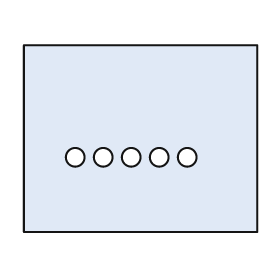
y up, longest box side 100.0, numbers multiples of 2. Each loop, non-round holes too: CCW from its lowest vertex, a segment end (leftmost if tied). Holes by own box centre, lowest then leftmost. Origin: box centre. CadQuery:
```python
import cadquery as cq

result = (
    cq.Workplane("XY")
    .moveTo(-50.0, -40.0)
    .lineTo(50.0, -40.0)
    .lineTo(50.0, 40.0)
    .lineTo(-50.0, 40.0)
    .close()
    .moveTo(-28.0, -8.0)
    .circle(4.0)
    .moveTo(-16.0, -8.0)
    .circle(4.0)
    .moveTo(-4.0, -8.0)
    .circle(4.0)
    .moveTo(8.0, -8.0)
    .circle(4.0)
    .moveTo(20.0, -8.0)
    .circle(4.0)
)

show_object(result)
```